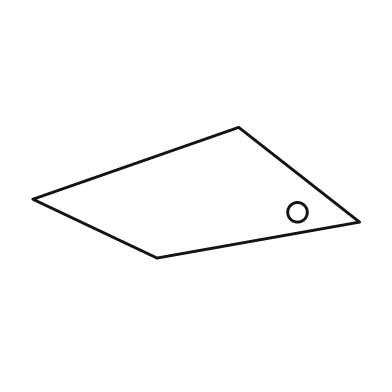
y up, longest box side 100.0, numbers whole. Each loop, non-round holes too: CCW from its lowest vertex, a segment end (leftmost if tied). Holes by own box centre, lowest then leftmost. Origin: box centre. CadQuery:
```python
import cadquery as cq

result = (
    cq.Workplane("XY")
    .moveTo(-12.0, -20.0)
    .lineTo(50.0, -9.0)
    .lineTo(13.0, 20.0)
    .lineTo(-50.0, -2.0)
    .close()
    .moveTo(31.0, -6.0)
    .circle(3.0)
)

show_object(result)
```